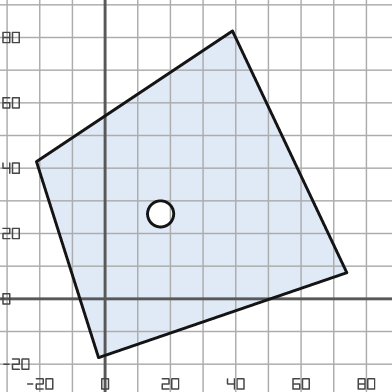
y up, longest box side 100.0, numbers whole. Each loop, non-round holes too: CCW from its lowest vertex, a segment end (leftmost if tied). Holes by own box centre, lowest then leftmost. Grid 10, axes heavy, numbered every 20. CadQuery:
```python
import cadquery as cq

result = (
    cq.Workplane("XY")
    .moveTo(-2.0, -18.0)
    .lineTo(74.0, 8.0)
    .lineTo(39.0, 82.0)
    .lineTo(-21.0, 42.0)
    .close()
    .moveTo(17.0, 26.0)
    .circle(4.0)
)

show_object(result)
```